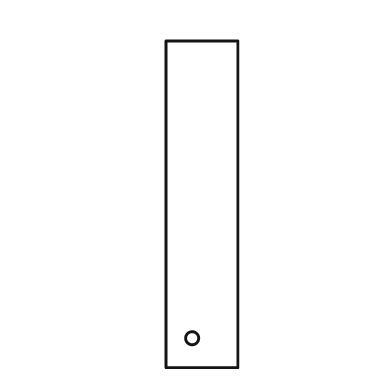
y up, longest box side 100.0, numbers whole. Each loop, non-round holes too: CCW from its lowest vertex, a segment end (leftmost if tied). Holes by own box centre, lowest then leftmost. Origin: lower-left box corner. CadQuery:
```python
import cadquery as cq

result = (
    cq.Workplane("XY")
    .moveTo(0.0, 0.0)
    .lineTo(22.0, 0.0)
    .lineTo(22.0, 100.0)
    .lineTo(0.0, 100.0)
    .close()
    .moveTo(8.0, 9.0)
    .circle(2.0)
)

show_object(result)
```